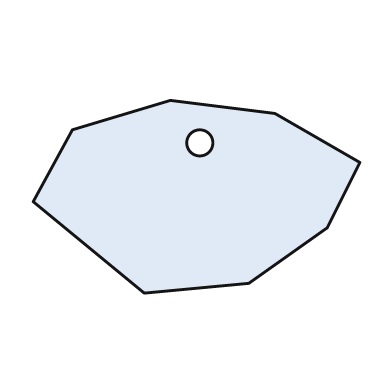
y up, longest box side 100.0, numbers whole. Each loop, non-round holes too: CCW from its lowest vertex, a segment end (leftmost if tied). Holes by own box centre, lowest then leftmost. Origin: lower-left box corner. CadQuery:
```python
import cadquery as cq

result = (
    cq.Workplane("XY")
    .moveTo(34.0, 0.0)
    .lineTo(66.0, 3.0)
    .lineTo(90.0, 20.0)
    .lineTo(100.0, 40.0)
    .lineTo(74.0, 55.0)
    .lineTo(42.0, 59.0)
    .lineTo(12.0, 50.0)
    .lineTo(0.0, 28.0)
    .close()
    .moveTo(51.0, 46.0)
    .circle(4.0)
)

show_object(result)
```